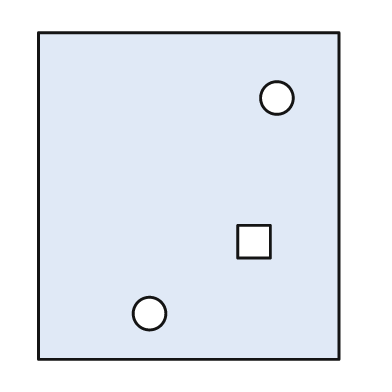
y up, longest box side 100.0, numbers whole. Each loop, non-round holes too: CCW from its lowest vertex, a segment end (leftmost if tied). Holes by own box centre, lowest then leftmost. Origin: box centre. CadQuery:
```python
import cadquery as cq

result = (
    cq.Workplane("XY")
    .moveTo(-46.0, -50.0)
    .lineTo(46.0, -50.0)
    .lineTo(46.0, 50.0)
    .lineTo(-46.0, 50.0)
    .close()
    .moveTo(-12.0, -36.0)
    .circle(5.0)
    .moveTo(15.0, -19.0)
    .lineTo(25.0, -19.0)
    .lineTo(25.0, -9.0)
    .lineTo(15.0, -9.0)
    .close()
    .moveTo(27.0, 30.0)
    .circle(5.0)
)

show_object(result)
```